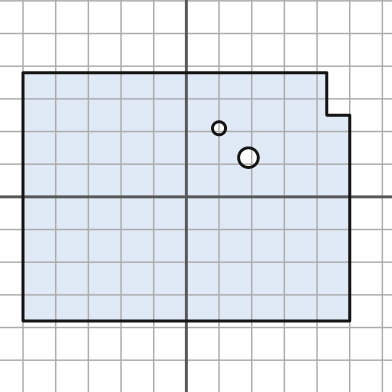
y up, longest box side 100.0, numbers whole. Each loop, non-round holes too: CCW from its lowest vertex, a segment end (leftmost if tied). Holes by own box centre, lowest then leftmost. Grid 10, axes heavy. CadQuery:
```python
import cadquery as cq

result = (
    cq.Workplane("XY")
    .moveTo(-50.0, -38.0)
    .lineTo(50.0, -38.0)
    .lineTo(50.0, 25.0)
    .lineTo(43.0, 25.0)
    .lineTo(43.0, 38.0)
    .lineTo(-50.0, 38.0)
    .close()
    .moveTo(19.0, 12.0)
    .circle(3.0)
    .moveTo(10.0, 21.0)
    .circle(2.0)
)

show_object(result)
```